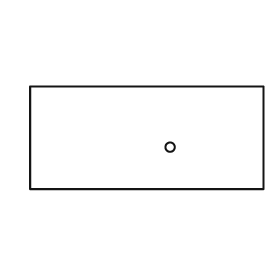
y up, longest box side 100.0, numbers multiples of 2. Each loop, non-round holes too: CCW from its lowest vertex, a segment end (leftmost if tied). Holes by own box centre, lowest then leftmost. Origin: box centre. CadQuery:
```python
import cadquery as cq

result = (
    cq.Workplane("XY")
    .moveTo(-50.0, -22.0)
    .lineTo(50.0, -22.0)
    .lineTo(50.0, 22.0)
    .lineTo(-50.0, 22.0)
    .close()
    .moveTo(10.0, -4.0)
    .circle(2.0)
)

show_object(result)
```